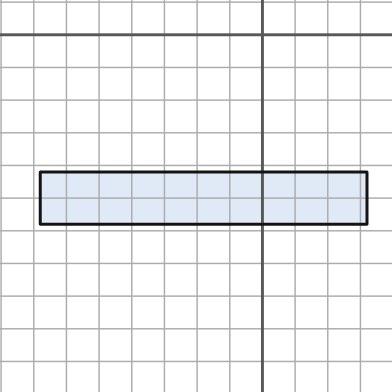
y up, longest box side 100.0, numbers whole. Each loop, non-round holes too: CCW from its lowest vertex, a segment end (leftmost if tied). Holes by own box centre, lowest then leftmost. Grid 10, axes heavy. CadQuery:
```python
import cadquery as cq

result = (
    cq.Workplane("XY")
    .moveTo(-68.0, -58.0)
    .lineTo(32.0, -58.0)
    .lineTo(32.0, -42.0)
    .lineTo(-68.0, -42.0)
    .close()
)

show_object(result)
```